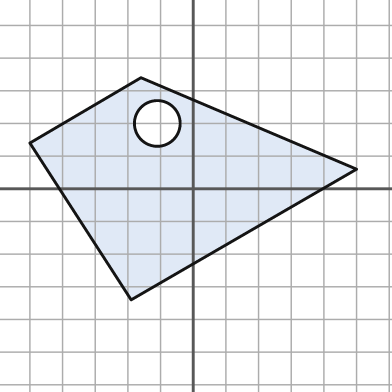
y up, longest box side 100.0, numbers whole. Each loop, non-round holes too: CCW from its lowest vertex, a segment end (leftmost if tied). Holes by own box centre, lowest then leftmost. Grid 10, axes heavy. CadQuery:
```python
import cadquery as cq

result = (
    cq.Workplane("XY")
    .moveTo(-19.0, -34.0)
    .lineTo(50.0, 6.0)
    .lineTo(-16.0, 34.0)
    .lineTo(-50.0, 14.0)
    .close()
    .moveTo(-11.0, 20.0)
    .circle(7.0)
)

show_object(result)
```